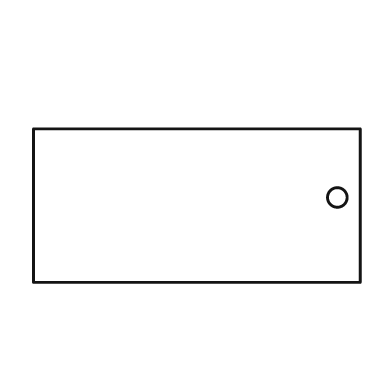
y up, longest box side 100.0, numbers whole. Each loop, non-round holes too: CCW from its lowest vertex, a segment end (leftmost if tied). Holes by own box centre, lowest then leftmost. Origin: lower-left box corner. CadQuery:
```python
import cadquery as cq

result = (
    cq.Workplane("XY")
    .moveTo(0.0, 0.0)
    .lineTo(100.0, 0.0)
    .lineTo(100.0, 47.0)
    .lineTo(0.0, 47.0)
    .close()
    .moveTo(93.0, 26.0)
    .circle(3.0)
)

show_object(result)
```